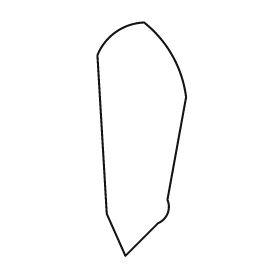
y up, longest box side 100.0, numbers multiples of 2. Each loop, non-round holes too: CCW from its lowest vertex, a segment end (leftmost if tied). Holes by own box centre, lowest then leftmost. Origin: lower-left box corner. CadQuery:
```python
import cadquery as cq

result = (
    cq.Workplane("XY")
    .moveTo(12.0, 0.0)
    .lineTo(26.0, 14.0)
    .threePointArc((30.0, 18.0), (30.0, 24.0))
    .lineTo(38.0, 68.0)
    .threePointArc((32.0, 86.0), (20.0, 100.0))
    .threePointArc((8.0, 96.0), (0.0, 86.0))
    .lineTo(4.0, 18.0)
    .close()
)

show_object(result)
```